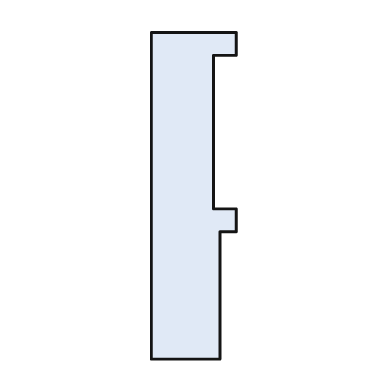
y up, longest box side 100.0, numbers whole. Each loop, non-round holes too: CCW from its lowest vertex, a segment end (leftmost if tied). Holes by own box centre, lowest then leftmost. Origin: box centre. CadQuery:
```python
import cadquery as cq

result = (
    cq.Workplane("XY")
    .moveTo(-13.0, -50.0)
    .lineTo(8.0, -50.0)
    .lineTo(8.0, -11.0)
    .lineTo(13.0, -11.0)
    .lineTo(13.0, -4.0)
    .lineTo(6.0, -4.0)
    .lineTo(6.0, 43.0)
    .lineTo(13.0, 43.0)
    .lineTo(13.0, 50.0)
    .lineTo(-13.0, 50.0)
    .close()
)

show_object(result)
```